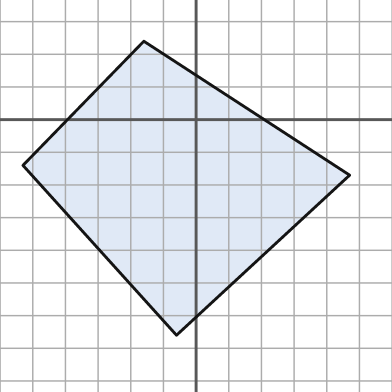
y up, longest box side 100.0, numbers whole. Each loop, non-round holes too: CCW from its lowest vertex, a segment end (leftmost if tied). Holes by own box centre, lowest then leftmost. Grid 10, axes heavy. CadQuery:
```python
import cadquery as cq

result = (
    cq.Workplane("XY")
    .moveTo(-6.0, -66.0)
    .lineTo(47.0, -17.0)
    .lineTo(-16.0, 24.0)
    .lineTo(-53.0, -14.0)
    .close()
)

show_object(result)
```